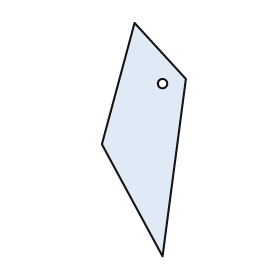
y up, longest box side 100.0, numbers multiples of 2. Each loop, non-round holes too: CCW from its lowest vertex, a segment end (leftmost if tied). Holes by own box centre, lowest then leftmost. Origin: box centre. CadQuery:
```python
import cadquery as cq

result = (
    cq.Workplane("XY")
    .moveTo(8.0, -50.0)
    .lineTo(18.0, 26.0)
    .lineTo(-4.0, 50.0)
    .lineTo(-18.0, -2.0)
    .close()
    .moveTo(8.0, 24.0)
    .circle(2.0)
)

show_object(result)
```